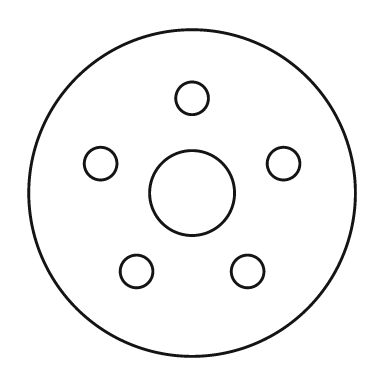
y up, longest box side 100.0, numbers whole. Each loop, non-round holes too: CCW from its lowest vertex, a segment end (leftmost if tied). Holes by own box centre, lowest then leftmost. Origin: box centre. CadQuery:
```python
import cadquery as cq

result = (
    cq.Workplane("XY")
    .moveTo(0.0, 0.0)
    .circle(50.0)
    .moveTo(-17.0, -24.0)
    .circle(5.0)
    .moveTo(17.0, -24.0)
    .circle(5.0)
    .moveTo(0.0, 0.0)
    .circle(13.0)
    .moveTo(-28.0, 9.0)
    .circle(5.0)
    .moveTo(28.0, 9.0)
    .circle(5.0)
    .moveTo(0.0, 29.0)
    .circle(5.0)
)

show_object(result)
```